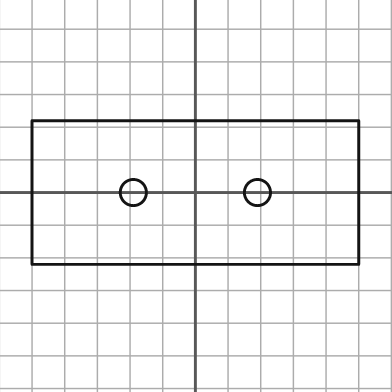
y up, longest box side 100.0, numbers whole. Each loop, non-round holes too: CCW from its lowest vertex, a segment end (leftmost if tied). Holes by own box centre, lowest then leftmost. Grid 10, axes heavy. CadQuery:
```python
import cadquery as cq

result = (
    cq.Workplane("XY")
    .moveTo(-50.0, -22.0)
    .lineTo(50.0, -22.0)
    .lineTo(50.0, 22.0)
    .lineTo(-50.0, 22.0)
    .close()
    .moveTo(-19.0, 0.0)
    .circle(4.0)
    .moveTo(19.0, 0.0)
    .circle(4.0)
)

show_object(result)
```